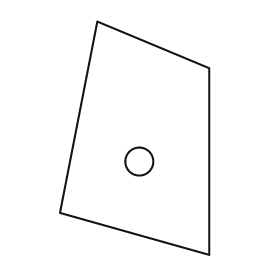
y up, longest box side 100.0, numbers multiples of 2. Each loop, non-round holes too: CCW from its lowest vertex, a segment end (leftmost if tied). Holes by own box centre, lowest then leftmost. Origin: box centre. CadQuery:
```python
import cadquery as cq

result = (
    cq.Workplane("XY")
    .moveTo(32.0, -50.0)
    .lineTo(32.0, 30.0)
    .lineTo(-16.0, 50.0)
    .lineTo(-32.0, -32.0)
    .close()
    .moveTo(2.0, -10.0)
    .circle(6.0)
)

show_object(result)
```